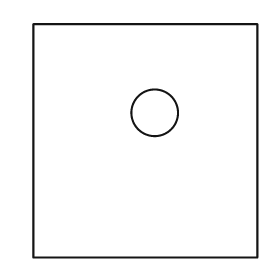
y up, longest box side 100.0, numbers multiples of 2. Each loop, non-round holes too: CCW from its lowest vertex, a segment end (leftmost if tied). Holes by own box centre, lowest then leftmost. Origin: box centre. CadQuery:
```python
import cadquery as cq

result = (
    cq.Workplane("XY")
    .moveTo(-48.0, -50.0)
    .lineTo(48.0, -50.0)
    .lineTo(48.0, 50.0)
    .lineTo(-48.0, 50.0)
    .close()
    .moveTo(4.0, 12.0)
    .circle(10.0)
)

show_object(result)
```